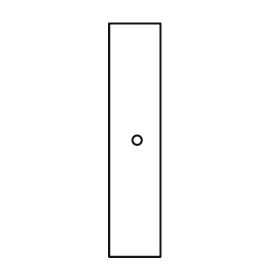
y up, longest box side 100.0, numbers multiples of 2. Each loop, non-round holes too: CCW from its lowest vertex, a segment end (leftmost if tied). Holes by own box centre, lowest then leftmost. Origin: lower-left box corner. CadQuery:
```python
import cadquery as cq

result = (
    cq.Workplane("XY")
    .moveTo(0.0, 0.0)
    .lineTo(22.0, 0.0)
    .lineTo(22.0, 100.0)
    .lineTo(0.0, 100.0)
    .close()
    .moveTo(12.0, 50.0)
    .circle(2.0)
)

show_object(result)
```